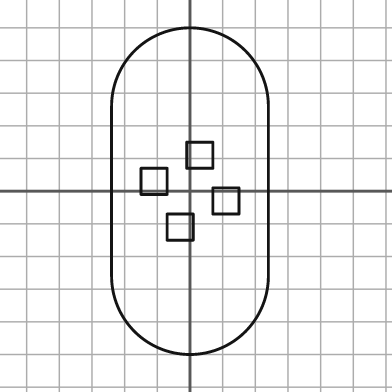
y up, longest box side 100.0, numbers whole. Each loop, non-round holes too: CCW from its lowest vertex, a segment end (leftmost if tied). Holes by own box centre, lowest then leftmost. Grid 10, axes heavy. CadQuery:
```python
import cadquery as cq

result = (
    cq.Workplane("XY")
    .moveTo(-24.0, -26.0)
    .threePointArc((0.0, -50.0), (24.0, -26.0))
    .lineTo(24.0, 26.0)
    .threePointArc((0.0, 50.0), (-24.0, 26.0))
    .close()
    .moveTo(-7.0, -15.0)
    .lineTo(1.0, -15.0)
    .lineTo(1.0, -7.0)
    .lineTo(-7.0, -7.0)
    .close()
    .moveTo(7.0, -7.0)
    .lineTo(15.0, -7.0)
    .lineTo(15.0, 1.0)
    .lineTo(7.0, 1.0)
    .close()
    .moveTo(-15.0, -1.0)
    .lineTo(-7.0, -1.0)
    .lineTo(-7.0, 7.0)
    .lineTo(-15.0, 7.0)
    .close()
    .moveTo(-1.0, 7.0)
    .lineTo(7.0, 7.0)
    .lineTo(7.0, 15.0)
    .lineTo(-1.0, 15.0)
    .close()
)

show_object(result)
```